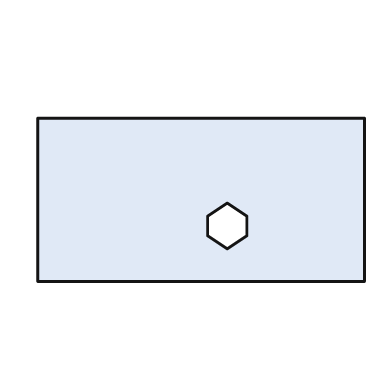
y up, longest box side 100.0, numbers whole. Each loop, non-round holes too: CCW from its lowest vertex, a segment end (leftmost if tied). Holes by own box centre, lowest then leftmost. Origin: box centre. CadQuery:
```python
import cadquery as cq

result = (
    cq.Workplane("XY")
    .moveTo(-50.0, -25.0)
    .lineTo(50.0, -25.0)
    .lineTo(50.0, 25.0)
    .lineTo(-50.0, 25.0)
    .close()
    .moveTo(8.0, -15.0)
    .lineTo(14.0, -11.0)
    .lineTo(14.0, -5.0)
    .lineTo(8.0, -1.0)
    .lineTo(2.0, -5.0)
    .lineTo(2.0, -11.0)
    .close()
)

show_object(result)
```